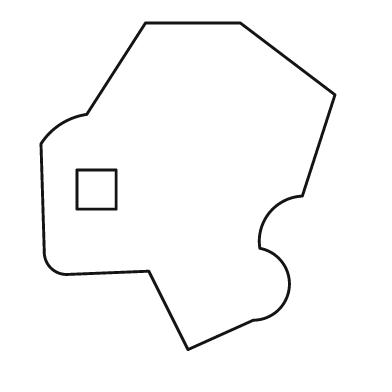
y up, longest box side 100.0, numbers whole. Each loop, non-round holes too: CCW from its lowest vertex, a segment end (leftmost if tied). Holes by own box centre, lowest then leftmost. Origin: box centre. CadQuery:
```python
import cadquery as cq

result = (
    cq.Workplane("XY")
    .moveTo(0.0, -50.0)
    .lineTo(20.0, -41.0)
    .threePointArc((31.0, -31.0), (22.0, -19.0))
    .threePointArc((25.0, -8.0), (35.0, -3.0))
    .lineTo(45.0, 28.0)
    .lineTo(16.0, 50.0)
    .lineTo(-13.0, 50.0)
    .lineTo(-31.0, 22.0)
    .threePointArc((-39.0, 19.0), (-45.0, 13.0))
    .lineTo(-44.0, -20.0)
    .threePointArc((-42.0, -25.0), (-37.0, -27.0))
    .lineTo(-12.0, -26.0)
    .close()
    .moveTo(-34.0, -7.0)
    .lineTo(-22.0, -7.0)
    .lineTo(-22.0, 5.0)
    .lineTo(-34.0, 5.0)
    .close()
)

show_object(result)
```